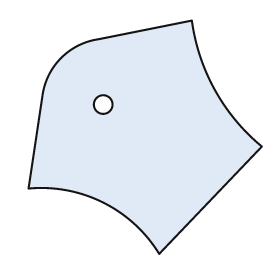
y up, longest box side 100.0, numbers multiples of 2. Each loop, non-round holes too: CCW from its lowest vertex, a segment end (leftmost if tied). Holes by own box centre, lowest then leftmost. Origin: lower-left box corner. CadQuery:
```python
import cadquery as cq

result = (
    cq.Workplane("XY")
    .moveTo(56.0, 0.0)
    .lineTo(100.0, 46.0)
    .threePointArc((80.0, 70.0), (70.0, 100.0))
    .lineTo(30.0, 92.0)
    .threePointArc((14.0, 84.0), (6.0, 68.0))
    .lineTo(0.0, 28.0)
    .threePointArc((32.0, 22.0), (56.0, 0.0))
    .close()
    .moveTo(32.0, 64.0)
    .circle(4.0)
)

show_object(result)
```